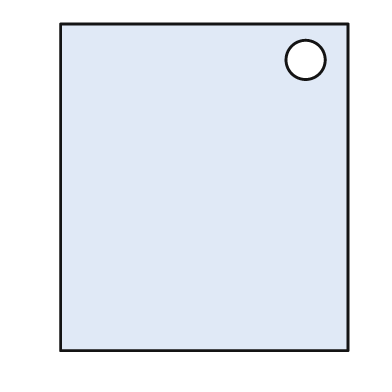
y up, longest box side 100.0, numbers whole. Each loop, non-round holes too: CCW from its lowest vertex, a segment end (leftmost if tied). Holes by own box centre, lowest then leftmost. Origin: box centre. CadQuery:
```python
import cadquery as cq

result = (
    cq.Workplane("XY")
    .moveTo(-44.0, -50.0)
    .lineTo(44.0, -50.0)
    .lineTo(44.0, 50.0)
    .lineTo(-44.0, 50.0)
    .close()
    .moveTo(31.0, 39.0)
    .circle(6.0)
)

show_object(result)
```